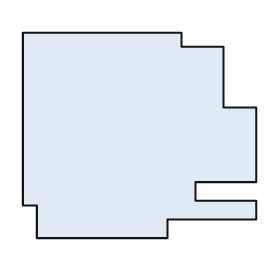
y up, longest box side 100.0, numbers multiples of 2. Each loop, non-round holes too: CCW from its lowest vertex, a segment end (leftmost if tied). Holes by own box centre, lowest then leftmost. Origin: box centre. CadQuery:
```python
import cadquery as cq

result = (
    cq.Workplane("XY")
    .moveTo(-44.0, -44.0)
    .lineTo(12.0, -44.0)
    .lineTo(12.0, -36.0)
    .lineTo(50.0, -36.0)
    .lineTo(50.0, -28.0)
    .lineTo(24.0, -28.0)
    .lineTo(24.0, -20.0)
    .lineTo(50.0, -20.0)
    .lineTo(50.0, 12.0)
    .lineTo(36.0, 12.0)
    .lineTo(36.0, 38.0)
    .lineTo(18.0, 38.0)
    .lineTo(18.0, 44.0)
    .lineTo(-50.0, 44.0)
    .lineTo(-50.0, -30.0)
    .lineTo(-44.0, -30.0)
    .close()
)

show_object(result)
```